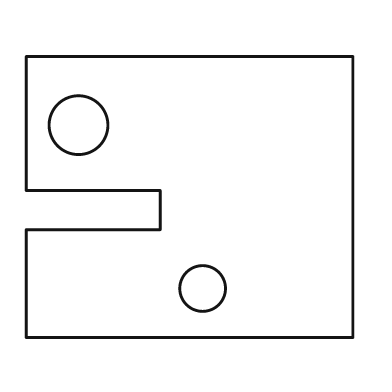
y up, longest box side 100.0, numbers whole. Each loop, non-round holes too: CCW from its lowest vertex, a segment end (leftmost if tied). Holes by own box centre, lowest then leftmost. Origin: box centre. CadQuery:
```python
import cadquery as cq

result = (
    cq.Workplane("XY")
    .moveTo(-50.0, -43.0)
    .lineTo(50.0, -43.0)
    .lineTo(50.0, 43.0)
    .lineTo(-50.0, 43.0)
    .lineTo(-50.0, 2.0)
    .lineTo(-9.0, 2.0)
    .lineTo(-9.0, -10.0)
    .lineTo(-50.0, -10.0)
    .close()
    .moveTo(4.0, -28.0)
    .circle(7.0)
    .moveTo(-34.0, 22.0)
    .circle(9.0)
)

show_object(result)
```